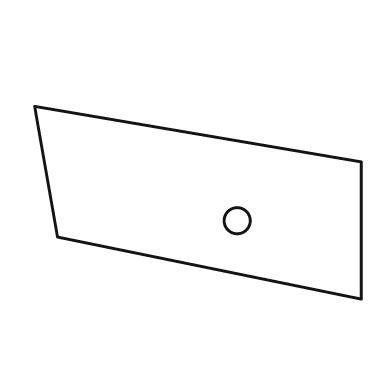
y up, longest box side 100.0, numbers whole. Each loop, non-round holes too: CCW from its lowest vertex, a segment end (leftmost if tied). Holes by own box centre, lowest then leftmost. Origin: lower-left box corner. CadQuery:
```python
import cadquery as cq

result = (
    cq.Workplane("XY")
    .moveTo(100.0, 0.0)
    .lineTo(100.0, 42.0)
    .lineTo(0.0, 59.0)
    .lineTo(7.0, 19.0)
    .close()
    .moveTo(62.0, 24.0)
    .circle(4.0)
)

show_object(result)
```